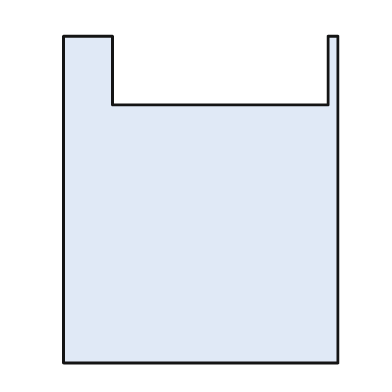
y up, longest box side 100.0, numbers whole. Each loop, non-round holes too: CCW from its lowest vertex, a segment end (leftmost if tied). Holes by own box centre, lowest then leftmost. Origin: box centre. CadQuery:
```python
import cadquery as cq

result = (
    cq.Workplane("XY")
    .moveTo(-42.0, -50.0)
    .lineTo(42.0, -50.0)
    .lineTo(42.0, 50.0)
    .lineTo(39.0, 50.0)
    .lineTo(39.0, 29.0)
    .lineTo(-27.0, 29.0)
    .lineTo(-27.0, 50.0)
    .lineTo(-42.0, 50.0)
    .close()
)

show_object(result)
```